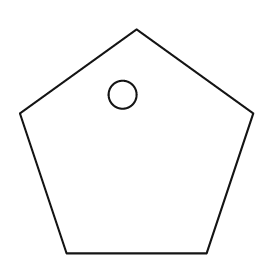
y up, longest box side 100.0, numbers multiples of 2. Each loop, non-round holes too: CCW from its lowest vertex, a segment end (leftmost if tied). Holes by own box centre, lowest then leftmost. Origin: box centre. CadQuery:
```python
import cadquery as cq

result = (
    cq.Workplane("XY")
    .moveTo(-30.0, -48.0)
    .lineTo(30.0, -48.0)
    .lineTo(50.0, 12.0)
    .lineTo(0.0, 48.0)
    .lineTo(-50.0, 12.0)
    .close()
    .moveTo(-6.0, 20.0)
    .circle(6.0)
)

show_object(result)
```